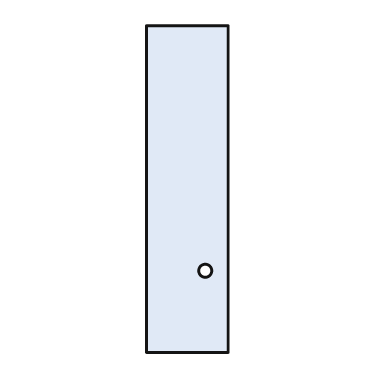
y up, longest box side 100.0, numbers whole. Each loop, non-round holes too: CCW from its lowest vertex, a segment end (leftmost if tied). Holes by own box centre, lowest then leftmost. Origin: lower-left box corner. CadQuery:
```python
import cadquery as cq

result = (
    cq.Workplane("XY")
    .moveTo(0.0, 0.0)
    .lineTo(25.0, 0.0)
    .lineTo(25.0, 100.0)
    .lineTo(0.0, 100.0)
    .close()
    .moveTo(18.0, 25.0)
    .circle(2.0)
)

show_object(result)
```